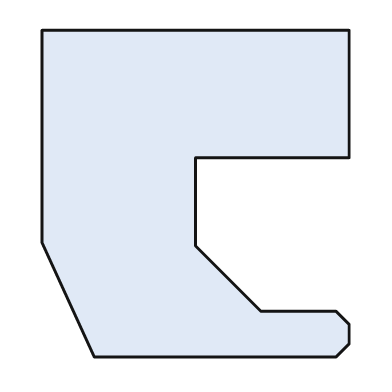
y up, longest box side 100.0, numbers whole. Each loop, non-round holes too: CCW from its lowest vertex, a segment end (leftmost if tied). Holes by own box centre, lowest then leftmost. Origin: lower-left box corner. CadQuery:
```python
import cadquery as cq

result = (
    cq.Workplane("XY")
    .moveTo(16.0, 0.0)
    .lineTo(90.0, 0.0)
    .lineTo(94.0, 4.0)
    .lineTo(94.0, 10.0)
    .lineTo(90.0, 14.0)
    .lineTo(67.0, 14.0)
    .lineTo(47.0, 34.0)
    .lineTo(47.0, 61.0)
    .lineTo(94.0, 61.0)
    .lineTo(94.0, 100.0)
    .lineTo(0.0, 100.0)
    .lineTo(0.0, 35.0)
    .close()
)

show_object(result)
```